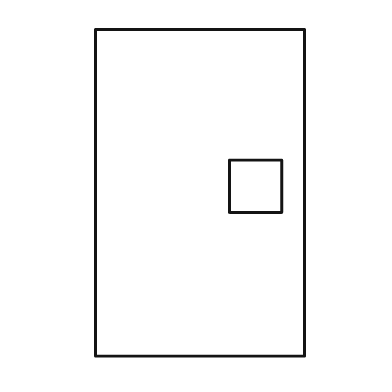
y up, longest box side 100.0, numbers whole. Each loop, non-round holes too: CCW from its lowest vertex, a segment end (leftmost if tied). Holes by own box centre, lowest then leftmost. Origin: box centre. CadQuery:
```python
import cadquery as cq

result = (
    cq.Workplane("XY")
    .moveTo(-32.0, -50.0)
    .lineTo(32.0, -50.0)
    .lineTo(32.0, 50.0)
    .lineTo(-32.0, 50.0)
    .close()
    .moveTo(9.0, -6.0)
    .lineTo(25.0, -6.0)
    .lineTo(25.0, 10.0)
    .lineTo(9.0, 10.0)
    .close()
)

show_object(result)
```